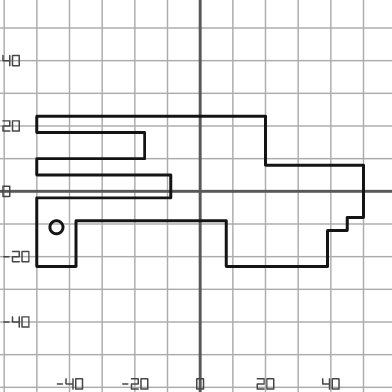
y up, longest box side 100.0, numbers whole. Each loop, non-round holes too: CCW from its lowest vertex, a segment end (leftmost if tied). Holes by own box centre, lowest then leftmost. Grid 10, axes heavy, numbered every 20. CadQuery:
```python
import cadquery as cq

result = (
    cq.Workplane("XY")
    .moveTo(-50.0, -23.0)
    .lineTo(-38.0, -23.0)
    .lineTo(-38.0, -9.0)
    .lineTo(8.0, -9.0)
    .lineTo(8.0, -23.0)
    .lineTo(39.0, -23.0)
    .lineTo(39.0, -12.0)
    .lineTo(45.0, -12.0)
    .lineTo(45.0, -8.0)
    .lineTo(50.0, -8.0)
    .lineTo(50.0, 8.0)
    .lineTo(20.0, 8.0)
    .lineTo(20.0, 23.0)
    .lineTo(-50.0, 23.0)
    .lineTo(-50.0, 18.0)
    .lineTo(-17.0, 18.0)
    .lineTo(-17.0, 10.0)
    .lineTo(-50.0, 10.0)
    .lineTo(-50.0, 5.0)
    .lineTo(-9.0, 5.0)
    .lineTo(-9.0, -2.0)
    .lineTo(-50.0, -2.0)
    .close()
    .moveTo(-44.0, -11.0)
    .circle(2.0)
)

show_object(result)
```